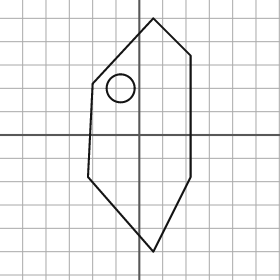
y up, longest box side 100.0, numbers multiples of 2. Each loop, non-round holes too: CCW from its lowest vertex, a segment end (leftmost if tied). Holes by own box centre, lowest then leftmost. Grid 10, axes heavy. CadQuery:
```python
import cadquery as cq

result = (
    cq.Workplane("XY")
    .moveTo(6.0, -50.0)
    .lineTo(22.0, -18.0)
    .lineTo(22.0, 34.0)
    .lineTo(6.0, 50.0)
    .lineTo(-20.0, 22.0)
    .lineTo(-22.0, -18.0)
    .close()
    .moveTo(-8.0, 20.0)
    .circle(6.0)
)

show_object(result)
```